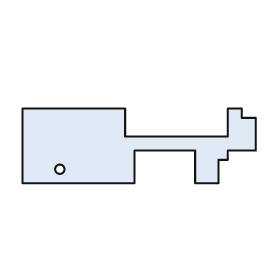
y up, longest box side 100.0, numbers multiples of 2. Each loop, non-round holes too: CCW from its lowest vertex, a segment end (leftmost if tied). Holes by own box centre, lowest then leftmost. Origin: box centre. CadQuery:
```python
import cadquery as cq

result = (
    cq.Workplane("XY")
    .moveTo(-50.0, -16.0)
    .lineTo(-2.0, -16.0)
    .lineTo(-2.0, -2.0)
    .lineTo(24.0, -2.0)
    .lineTo(24.0, -16.0)
    .lineTo(34.0, -16.0)
    .lineTo(34.0, -6.0)
    .lineTo(38.0, -6.0)
    .lineTo(38.0, -2.0)
    .lineTo(50.0, -2.0)
    .lineTo(50.0, 12.0)
    .lineTo(44.0, 12.0)
    .lineTo(44.0, 16.0)
    .lineTo(38.0, 16.0)
    .lineTo(38.0, 4.0)
    .lineTo(-6.0, 4.0)
    .lineTo(-6.0, 16.0)
    .lineTo(-50.0, 16.0)
    .close()
    .moveTo(-34.0, -10.0)
    .circle(2.0)
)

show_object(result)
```